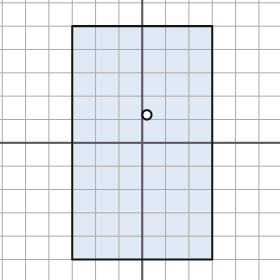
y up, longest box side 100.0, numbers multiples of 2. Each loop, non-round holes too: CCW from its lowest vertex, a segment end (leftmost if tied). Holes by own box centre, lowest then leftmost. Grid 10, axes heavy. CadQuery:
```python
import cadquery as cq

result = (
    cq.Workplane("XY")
    .moveTo(-30.0, -50.0)
    .lineTo(30.0, -50.0)
    .lineTo(30.0, 50.0)
    .lineTo(-30.0, 50.0)
    .close()
    .moveTo(2.0, 12.0)
    .circle(2.0)
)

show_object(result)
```